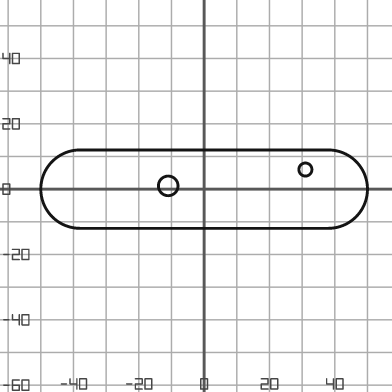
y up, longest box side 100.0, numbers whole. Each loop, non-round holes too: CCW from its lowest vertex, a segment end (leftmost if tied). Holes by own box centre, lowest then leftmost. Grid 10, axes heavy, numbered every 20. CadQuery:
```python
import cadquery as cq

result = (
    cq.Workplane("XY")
    .moveTo(-38.0, -12.0)
    .lineTo(38.0, -12.0)
    .threePointArc((50.0, 0.0), (38.0, 12.0))
    .lineTo(-38.0, 12.0)
    .threePointArc((-50.0, 0.0), (-38.0, -12.0))
    .close()
    .moveTo(-11.0, 1.0)
    .circle(3.0)
    .moveTo(31.0, 6.0)
    .circle(2.0)
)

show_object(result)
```